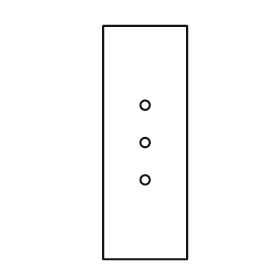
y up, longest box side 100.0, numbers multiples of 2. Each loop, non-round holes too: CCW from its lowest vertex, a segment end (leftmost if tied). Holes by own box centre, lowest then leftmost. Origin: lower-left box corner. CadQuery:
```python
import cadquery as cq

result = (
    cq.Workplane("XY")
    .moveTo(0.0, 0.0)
    .lineTo(36.0, 0.0)
    .lineTo(36.0, 100.0)
    .lineTo(0.0, 100.0)
    .close()
    .moveTo(18.0, 34.0)
    .circle(2.0)
    .moveTo(18.0, 50.0)
    .circle(2.0)
    .moveTo(18.0, 66.0)
    .circle(2.0)
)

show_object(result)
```